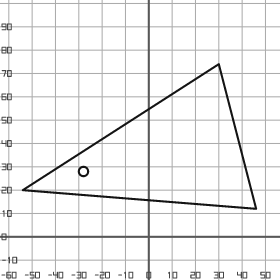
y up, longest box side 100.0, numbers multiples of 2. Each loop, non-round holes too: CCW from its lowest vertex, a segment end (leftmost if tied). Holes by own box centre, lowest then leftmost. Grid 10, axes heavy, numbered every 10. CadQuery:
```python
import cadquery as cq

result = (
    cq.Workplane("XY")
    .moveTo(46.0, 12.0)
    .lineTo(30.0, 74.0)
    .lineTo(-54.0, 20.0)
    .close()
    .moveTo(-28.0, 28.0)
    .circle(2.0)
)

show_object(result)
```